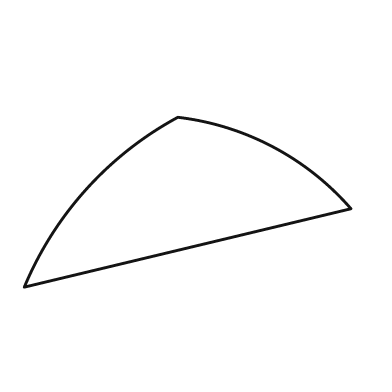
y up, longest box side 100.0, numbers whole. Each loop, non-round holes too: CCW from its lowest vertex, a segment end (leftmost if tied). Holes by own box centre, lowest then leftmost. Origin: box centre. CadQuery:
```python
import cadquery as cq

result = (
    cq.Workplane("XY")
    .moveTo(-50.0, -26.0)
    .lineTo(50.0, -2.0)
    .threePointArc((26.0, 17.0), (-3.0, 26.0))
    .threePointArc((-31.0, 4.0), (-50.0, -26.0))
    .close()
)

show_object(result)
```